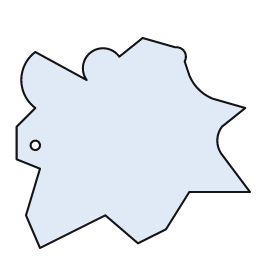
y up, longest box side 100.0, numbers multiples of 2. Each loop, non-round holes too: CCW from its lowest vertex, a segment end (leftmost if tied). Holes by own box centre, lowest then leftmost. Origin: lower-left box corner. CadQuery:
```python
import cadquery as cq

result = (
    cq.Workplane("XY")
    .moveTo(10.0, 0.0)
    .lineTo(38.0, 14.0)
    .lineTo(52.0, 2.0)
    .lineTo(64.0, 8.0)
    .lineTo(74.0, 24.0)
    .lineTo(100.0, 24.0)
    .lineTo(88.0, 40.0)
    .threePointArc((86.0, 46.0), (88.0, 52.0))
    .lineTo(98.0, 60.0)
    .lineTo(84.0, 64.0)
    .threePointArc((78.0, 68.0), (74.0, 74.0))
    .lineTo(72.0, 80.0)
    .threePointArc((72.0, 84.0), (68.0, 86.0))
    .lineTo(54.0, 90.0)
    .lineTo(44.0, 82.0)
    .threePointArc((32.0, 84.0), (30.0, 72.0))
    .lineTo(8.0, 84.0)
    .threePointArc((2.0, 72.0), (8.0, 60.0))
    .lineTo(0.0, 52.0)
    .lineTo(0.0, 38.0)
    .lineTo(10.0, 34.0)
    .lineTo(4.0, 14.0)
    .close()
    .moveTo(8.0, 44.0)
    .circle(2.0)
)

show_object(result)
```